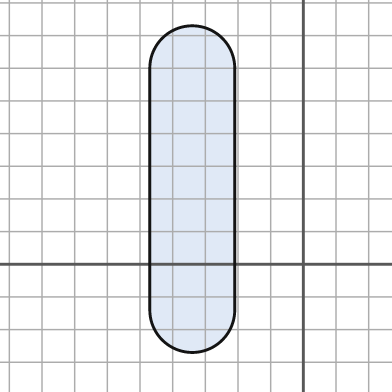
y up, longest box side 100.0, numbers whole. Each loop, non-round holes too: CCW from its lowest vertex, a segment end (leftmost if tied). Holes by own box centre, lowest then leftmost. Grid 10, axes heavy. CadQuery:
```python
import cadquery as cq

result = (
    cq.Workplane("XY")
    .moveTo(-47.0, -14.0)
    .threePointArc((-34.0, -27.0), (-21.0, -14.0))
    .lineTo(-21.0, 60.0)
    .threePointArc((-34.0, 73.0), (-47.0, 60.0))
    .close()
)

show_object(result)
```